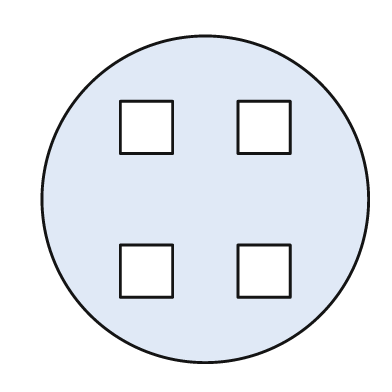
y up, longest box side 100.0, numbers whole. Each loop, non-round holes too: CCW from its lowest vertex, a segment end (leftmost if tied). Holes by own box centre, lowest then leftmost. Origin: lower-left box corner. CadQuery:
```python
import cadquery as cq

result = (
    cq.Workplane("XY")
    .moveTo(50.0, 50.0)
    .circle(50.0)
    .moveTo(24.0, 20.0)
    .lineTo(40.0, 20.0)
    .lineTo(40.0, 36.0)
    .lineTo(24.0, 36.0)
    .close()
    .moveTo(60.0, 20.0)
    .lineTo(76.0, 20.0)
    .lineTo(76.0, 36.0)
    .lineTo(60.0, 36.0)
    .close()
    .moveTo(24.0, 64.0)
    .lineTo(40.0, 64.0)
    .lineTo(40.0, 80.0)
    .lineTo(24.0, 80.0)
    .close()
    .moveTo(60.0, 64.0)
    .lineTo(76.0, 64.0)
    .lineTo(76.0, 80.0)
    .lineTo(60.0, 80.0)
    .close()
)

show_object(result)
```